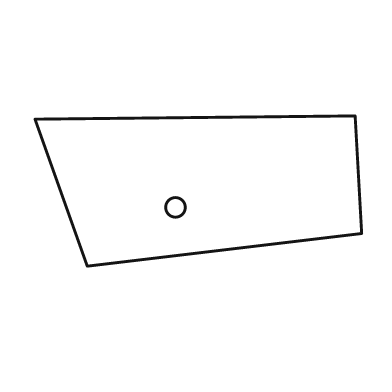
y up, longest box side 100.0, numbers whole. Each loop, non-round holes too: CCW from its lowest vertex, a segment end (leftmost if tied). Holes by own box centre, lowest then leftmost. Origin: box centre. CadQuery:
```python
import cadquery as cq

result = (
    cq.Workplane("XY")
    .moveTo(-34.0, -23.0)
    .lineTo(50.0, -13.0)
    .lineTo(48.0, 23.0)
    .lineTo(-50.0, 22.0)
    .close()
    .moveTo(-7.0, -5.0)
    .circle(3.0)
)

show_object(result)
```